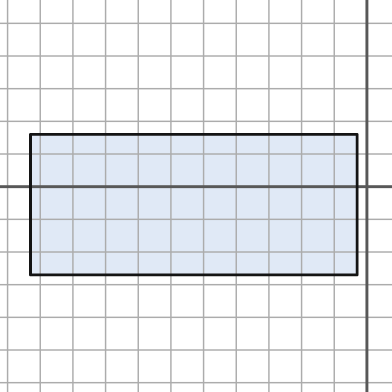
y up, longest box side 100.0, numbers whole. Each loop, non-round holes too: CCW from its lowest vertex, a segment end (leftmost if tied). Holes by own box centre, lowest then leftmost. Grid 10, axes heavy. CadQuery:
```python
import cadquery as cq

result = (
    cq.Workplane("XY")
    .moveTo(-103.0, -27.0)
    .lineTo(-3.0, -27.0)
    .lineTo(-3.0, 16.0)
    .lineTo(-103.0, 16.0)
    .close()
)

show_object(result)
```